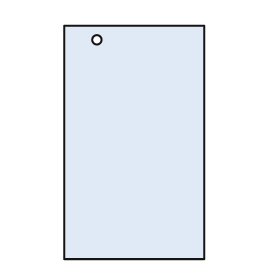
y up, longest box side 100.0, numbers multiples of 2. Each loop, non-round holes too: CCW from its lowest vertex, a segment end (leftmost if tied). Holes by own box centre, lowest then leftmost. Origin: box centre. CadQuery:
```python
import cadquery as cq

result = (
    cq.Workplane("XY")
    .moveTo(-30.0, -50.0)
    .lineTo(30.0, -50.0)
    .lineTo(30.0, 50.0)
    .lineTo(-30.0, 50.0)
    .close()
    .moveTo(-16.0, 44.0)
    .circle(2.0)
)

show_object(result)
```